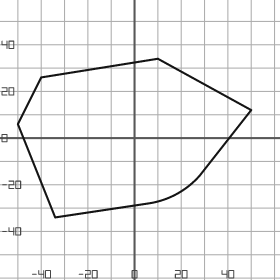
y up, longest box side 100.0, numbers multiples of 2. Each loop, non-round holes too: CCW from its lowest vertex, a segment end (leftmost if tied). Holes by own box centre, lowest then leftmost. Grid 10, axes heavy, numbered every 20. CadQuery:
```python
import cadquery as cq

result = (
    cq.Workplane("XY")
    .moveTo(-34.0, -34.0)
    .lineTo(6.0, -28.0)
    .threePointArc((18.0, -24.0), (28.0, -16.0))
    .lineTo(50.0, 12.0)
    .lineTo(10.0, 34.0)
    .lineTo(-40.0, 26.0)
    .lineTo(-50.0, 6.0)
    .close()
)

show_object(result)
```